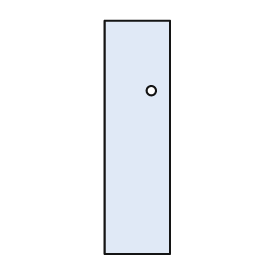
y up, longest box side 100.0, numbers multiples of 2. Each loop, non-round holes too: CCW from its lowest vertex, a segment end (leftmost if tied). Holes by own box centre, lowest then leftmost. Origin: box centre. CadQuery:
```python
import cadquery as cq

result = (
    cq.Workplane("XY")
    .moveTo(-14.0, -50.0)
    .lineTo(14.0, -50.0)
    .lineTo(14.0, 50.0)
    .lineTo(-14.0, 50.0)
    .close()
    .moveTo(6.0, 20.0)
    .circle(2.0)
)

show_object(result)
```